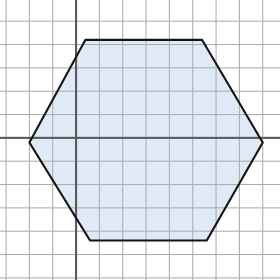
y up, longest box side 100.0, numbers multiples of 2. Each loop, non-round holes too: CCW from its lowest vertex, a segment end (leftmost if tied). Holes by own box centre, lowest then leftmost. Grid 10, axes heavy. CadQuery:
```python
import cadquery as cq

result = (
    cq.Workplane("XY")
    .moveTo(6.0, -44.0)
    .lineTo(56.0, -44.0)
    .lineTo(80.0, -2.0)
    .lineTo(54.0, 42.0)
    .lineTo(4.0, 42.0)
    .lineTo(-20.0, -2.0)
    .close()
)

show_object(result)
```